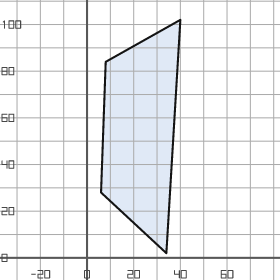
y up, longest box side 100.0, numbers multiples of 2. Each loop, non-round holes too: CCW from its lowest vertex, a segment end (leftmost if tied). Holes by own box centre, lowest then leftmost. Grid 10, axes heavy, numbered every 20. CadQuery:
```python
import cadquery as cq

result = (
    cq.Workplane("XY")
    .moveTo(34.0, 2.0)
    .lineTo(40.0, 102.0)
    .lineTo(8.0, 84.0)
    .lineTo(6.0, 28.0)
    .close()
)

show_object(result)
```